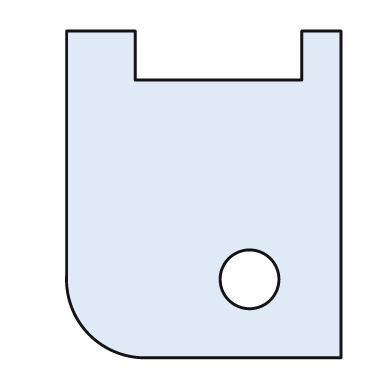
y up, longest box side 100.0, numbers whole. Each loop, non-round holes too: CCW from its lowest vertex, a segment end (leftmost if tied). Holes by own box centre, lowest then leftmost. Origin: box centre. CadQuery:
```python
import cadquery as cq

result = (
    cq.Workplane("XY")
    .moveTo(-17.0, -50.0)
    .lineTo(42.0, -50.0)
    .lineTo(42.0, 50.0)
    .lineTo(30.0, 50.0)
    .lineTo(30.0, 35.0)
    .lineTo(-21.0, 35.0)
    .lineTo(-21.0, 50.0)
    .lineTo(-42.0, 50.0)
    .lineTo(-42.0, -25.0)
    .threePointArc((-35.0, -43.0), (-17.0, -50.0))
    .close()
    .moveTo(14.0, -26.0)
    .circle(9.0)
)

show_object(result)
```